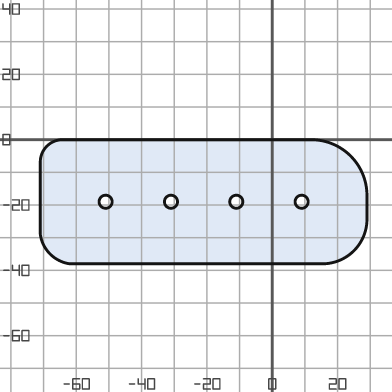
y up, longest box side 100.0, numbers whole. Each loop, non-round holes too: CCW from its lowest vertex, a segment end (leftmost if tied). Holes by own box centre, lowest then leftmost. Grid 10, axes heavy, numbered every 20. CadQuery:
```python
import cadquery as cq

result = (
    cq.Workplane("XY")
    .moveTo(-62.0, -38.0)
    .lineTo(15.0, -38.0)
    .threePointArc((25.0, -34.0), (29.0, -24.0))
    .lineTo(29.0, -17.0)
    .threePointArc((24.0, -5.0), (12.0, 0.0))
    .lineTo(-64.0, 0.0)
    .threePointArc((-69.0, -2.0), (-71.0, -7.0))
    .lineTo(-71.0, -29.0)
    .threePointArc((-68.0, -35.0), (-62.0, -38.0))
    .close()
    .moveTo(-51.0, -19.0)
    .circle(2.0)
    .moveTo(-31.0, -19.0)
    .circle(2.0)
    .moveTo(-11.0, -19.0)
    .circle(2.0)
    .moveTo(9.0, -19.0)
    .circle(2.0)
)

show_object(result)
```